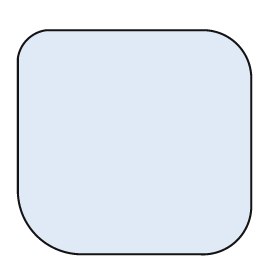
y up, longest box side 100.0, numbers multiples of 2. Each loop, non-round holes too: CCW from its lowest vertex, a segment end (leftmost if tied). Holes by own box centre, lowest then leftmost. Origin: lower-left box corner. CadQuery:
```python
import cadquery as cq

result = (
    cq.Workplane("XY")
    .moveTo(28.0, 0.0)
    .lineTo(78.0, 0.0)
    .threePointArc((94.0, 6.0), (100.0, 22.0))
    .lineTo(100.0, 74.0)
    .threePointArc((94.0, 90.0), (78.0, 96.0))
    .lineTo(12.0, 96.0)
    .threePointArc((4.0, 92.0), (0.0, 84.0))
    .lineTo(0.0, 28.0)
    .threePointArc((8.0, 8.0), (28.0, 0.0))
    .close()
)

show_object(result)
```